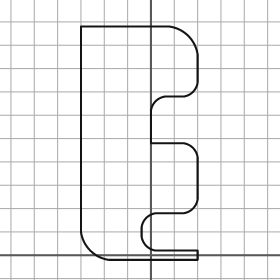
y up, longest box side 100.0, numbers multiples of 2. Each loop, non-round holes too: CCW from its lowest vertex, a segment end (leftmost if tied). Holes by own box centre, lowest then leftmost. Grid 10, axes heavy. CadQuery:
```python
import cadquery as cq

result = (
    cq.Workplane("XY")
    .moveTo(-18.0, -2.0)
    .lineTo(20.0, -2.0)
    .lineTo(20.0, 2.0)
    .lineTo(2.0, 2.0)
    .threePointArc((-2.0, 4.0), (-4.0, 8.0))
    .lineTo(-4.0, 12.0)
    .threePointArc((-2.0, 16.0), (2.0, 18.0))
    .lineTo(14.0, 18.0)
    .threePointArc((18.0, 20.0), (20.0, 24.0))
    .lineTo(20.0, 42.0)
    .threePointArc((18.0, 46.0), (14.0, 48.0))
    .lineTo(0.0, 48.0)
    .lineTo(0.0, 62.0)
    .threePointArc((2.0, 66.0), (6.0, 68.0))
    .lineTo(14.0, 68.0)
    .threePointArc((18.0, 70.0), (20.0, 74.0))
    .lineTo(20.0, 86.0)
    .threePointArc((16.0, 94.0), (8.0, 98.0))
    .lineTo(-30.0, 98.0)
    .lineTo(-30.0, 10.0)
    .threePointArc((-26.0, 2.0), (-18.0, -2.0))
    .close()
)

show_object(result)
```